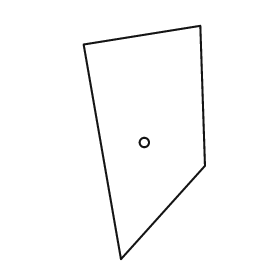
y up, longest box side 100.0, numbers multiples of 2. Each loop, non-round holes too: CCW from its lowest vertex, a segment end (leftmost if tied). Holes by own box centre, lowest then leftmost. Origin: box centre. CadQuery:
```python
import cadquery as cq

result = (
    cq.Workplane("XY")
    .moveTo(-10.0, -50.0)
    .lineTo(26.0, -10.0)
    .lineTo(24.0, 50.0)
    .lineTo(-26.0, 42.0)
    .close()
    .moveTo(0.0, 0.0)
    .circle(2.0)
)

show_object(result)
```